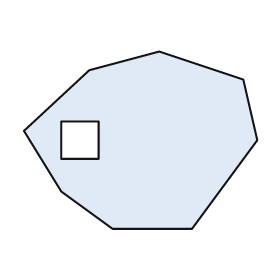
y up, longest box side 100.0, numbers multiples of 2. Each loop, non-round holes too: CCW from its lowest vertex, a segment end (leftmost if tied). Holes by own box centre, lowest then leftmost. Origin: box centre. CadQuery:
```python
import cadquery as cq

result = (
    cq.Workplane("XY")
    .moveTo(-12.0, -38.0)
    .lineTo(22.0, -38.0)
    .lineTo(50.0, 0.0)
    .lineTo(44.0, 26.0)
    .lineTo(8.0, 38.0)
    .lineTo(-22.0, 30.0)
    .lineTo(-50.0, 4.0)
    .lineTo(-34.0, -22.0)
    .close()
    .moveTo(-34.0, -8.0)
    .lineTo(-18.0, -8.0)
    .lineTo(-18.0, 8.0)
    .lineTo(-34.0, 8.0)
    .close()
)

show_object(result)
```